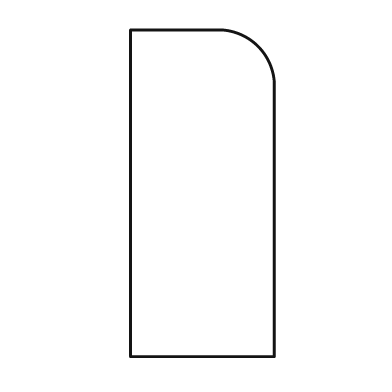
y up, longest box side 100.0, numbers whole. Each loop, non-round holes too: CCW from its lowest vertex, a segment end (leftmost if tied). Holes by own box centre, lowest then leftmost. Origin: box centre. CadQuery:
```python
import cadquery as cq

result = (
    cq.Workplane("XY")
    .moveTo(-22.0, -50.0)
    .lineTo(22.0, -50.0)
    .lineTo(22.0, 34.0)
    .threePointArc((17.0, 45.0), (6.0, 50.0))
    .lineTo(-22.0, 50.0)
    .close()
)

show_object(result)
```